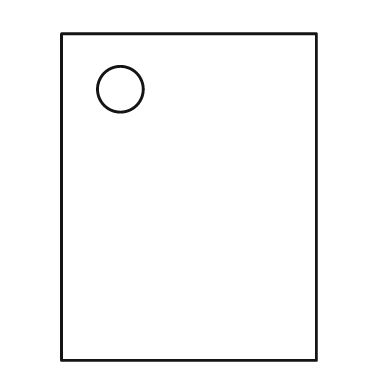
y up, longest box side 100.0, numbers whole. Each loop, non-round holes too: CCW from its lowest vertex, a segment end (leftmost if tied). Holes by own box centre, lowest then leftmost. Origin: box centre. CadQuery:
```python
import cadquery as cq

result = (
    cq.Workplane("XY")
    .moveTo(-39.0, -50.0)
    .lineTo(39.0, -50.0)
    .lineTo(39.0, 50.0)
    .lineTo(-39.0, 50.0)
    .close()
    .moveTo(-21.0, 33.0)
    .circle(7.0)
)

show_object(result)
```